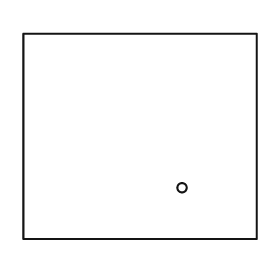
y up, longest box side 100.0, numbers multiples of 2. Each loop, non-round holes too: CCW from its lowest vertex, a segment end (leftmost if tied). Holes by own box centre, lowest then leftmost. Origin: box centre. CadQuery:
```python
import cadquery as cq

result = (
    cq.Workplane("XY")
    .moveTo(-50.0, -44.0)
    .lineTo(50.0, -44.0)
    .lineTo(50.0, 44.0)
    .lineTo(-50.0, 44.0)
    .close()
    .moveTo(18.0, -22.0)
    .circle(2.0)
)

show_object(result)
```